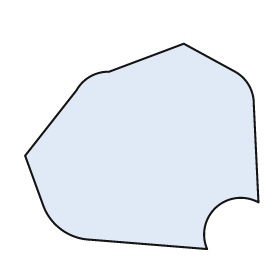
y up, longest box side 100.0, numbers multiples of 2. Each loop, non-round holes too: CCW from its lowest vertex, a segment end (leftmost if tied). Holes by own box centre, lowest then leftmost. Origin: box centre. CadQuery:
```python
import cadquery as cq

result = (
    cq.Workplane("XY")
    .moveTo(28.0, -44.0)
    .threePointArc((32.0, -26.0), (50.0, -24.0))
    .lineTo(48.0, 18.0)
    .threePointArc((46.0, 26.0), (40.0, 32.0))
    .lineTo(18.0, 44.0)
    .lineTo(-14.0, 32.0)
    .threePointArc((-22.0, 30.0), (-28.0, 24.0))
    .lineTo(-50.0, -4.0)
    .lineTo(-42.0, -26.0)
    .threePointArc((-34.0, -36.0), (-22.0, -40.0))
    .close()
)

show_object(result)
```